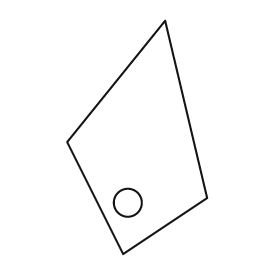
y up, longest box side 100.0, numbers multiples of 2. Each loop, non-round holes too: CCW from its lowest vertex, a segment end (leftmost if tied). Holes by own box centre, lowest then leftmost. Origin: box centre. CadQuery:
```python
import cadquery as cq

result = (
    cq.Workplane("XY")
    .moveTo(-6.0, -50.0)
    .lineTo(30.0, -26.0)
    .lineTo(12.0, 50.0)
    .lineTo(-30.0, -2.0)
    .close()
    .moveTo(-4.0, -28.0)
    .circle(6.0)
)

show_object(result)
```